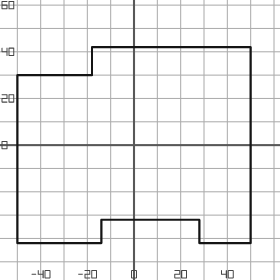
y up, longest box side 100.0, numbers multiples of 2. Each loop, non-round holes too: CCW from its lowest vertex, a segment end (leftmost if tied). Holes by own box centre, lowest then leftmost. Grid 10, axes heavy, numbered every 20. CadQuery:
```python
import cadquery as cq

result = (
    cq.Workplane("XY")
    .moveTo(-50.0, -42.0)
    .lineTo(-14.0, -42.0)
    .lineTo(-14.0, -32.0)
    .lineTo(28.0, -32.0)
    .lineTo(28.0, -42.0)
    .lineTo(50.0, -42.0)
    .lineTo(50.0, 42.0)
    .lineTo(-18.0, 42.0)
    .lineTo(-18.0, 30.0)
    .lineTo(-50.0, 30.0)
    .close()
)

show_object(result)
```